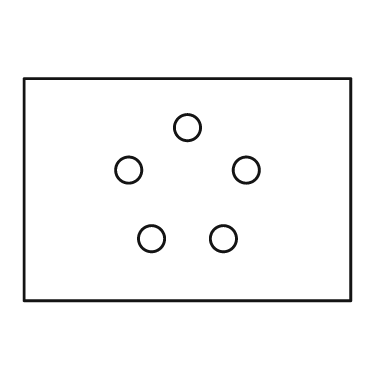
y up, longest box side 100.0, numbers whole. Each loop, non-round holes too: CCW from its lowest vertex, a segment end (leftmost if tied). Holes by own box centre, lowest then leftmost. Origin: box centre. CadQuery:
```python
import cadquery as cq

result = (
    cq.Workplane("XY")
    .moveTo(-50.0, -34.0)
    .lineTo(50.0, -34.0)
    .lineTo(50.0, 34.0)
    .lineTo(-50.0, 34.0)
    .close()
    .moveTo(-11.0, -15.0)
    .circle(4.0)
    .moveTo(11.0, -15.0)
    .circle(4.0)
    .moveTo(-18.0, 6.0)
    .circle(4.0)
    .moveTo(18.0, 6.0)
    .circle(4.0)
    .moveTo(0.0, 19.0)
    .circle(4.0)
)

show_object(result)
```